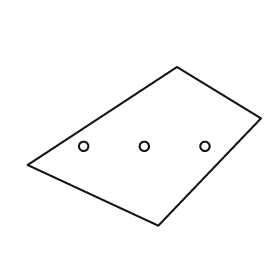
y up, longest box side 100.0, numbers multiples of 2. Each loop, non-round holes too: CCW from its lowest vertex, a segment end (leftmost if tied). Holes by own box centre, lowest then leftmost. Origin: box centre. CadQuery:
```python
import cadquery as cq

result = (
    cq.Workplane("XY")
    .moveTo(6.0, -34.0)
    .lineTo(50.0, 12.0)
    .lineTo(14.0, 34.0)
    .lineTo(-50.0, -8.0)
    .close()
    .moveTo(-26.0, 0.0)
    .circle(2.0)
    .moveTo(0.0, 0.0)
    .circle(2.0)
    .moveTo(26.0, 0.0)
    .circle(2.0)
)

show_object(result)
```